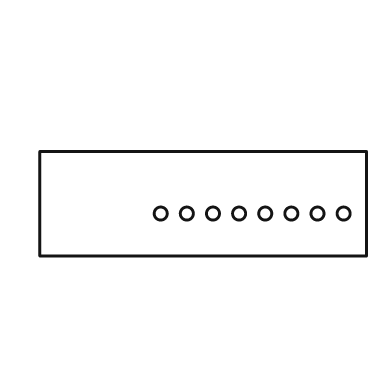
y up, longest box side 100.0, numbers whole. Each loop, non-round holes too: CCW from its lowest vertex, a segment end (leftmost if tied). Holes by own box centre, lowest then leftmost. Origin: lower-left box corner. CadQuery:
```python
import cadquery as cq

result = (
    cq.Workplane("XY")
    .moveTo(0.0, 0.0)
    .lineTo(100.0, 0.0)
    .lineTo(100.0, 32.0)
    .lineTo(0.0, 32.0)
    .close()
    .moveTo(37.0, 13.0)
    .circle(2.0)
    .moveTo(45.0, 13.0)
    .circle(2.0)
    .moveTo(53.0, 13.0)
    .circle(2.0)
    .moveTo(61.0, 13.0)
    .circle(2.0)
    .moveTo(69.0, 13.0)
    .circle(2.0)
    .moveTo(77.0, 13.0)
    .circle(2.0)
    .moveTo(85.0, 13.0)
    .circle(2.0)
    .moveTo(93.0, 13.0)
    .circle(2.0)
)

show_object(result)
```